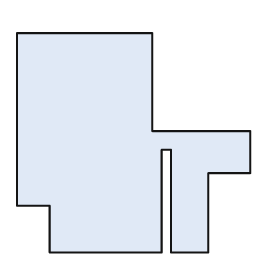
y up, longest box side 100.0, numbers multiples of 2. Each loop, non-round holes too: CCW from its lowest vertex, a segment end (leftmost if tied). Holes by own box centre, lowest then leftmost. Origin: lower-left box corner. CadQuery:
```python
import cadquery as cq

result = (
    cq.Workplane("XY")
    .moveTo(14.0, 0.0)
    .lineTo(62.0, 0.0)
    .lineTo(62.0, 44.0)
    .lineTo(66.0, 44.0)
    .lineTo(66.0, 0.0)
    .lineTo(82.0, 0.0)
    .lineTo(82.0, 34.0)
    .lineTo(100.0, 34.0)
    .lineTo(100.0, 52.0)
    .lineTo(58.0, 52.0)
    .lineTo(58.0, 94.0)
    .lineTo(0.0, 94.0)
    .lineTo(0.0, 20.0)
    .lineTo(14.0, 20.0)
    .close()
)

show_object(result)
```